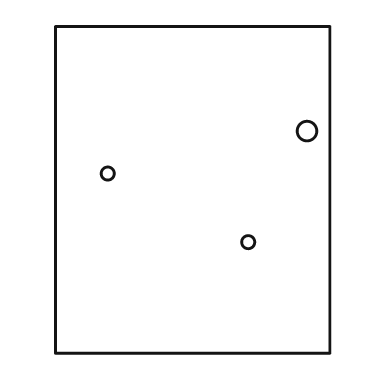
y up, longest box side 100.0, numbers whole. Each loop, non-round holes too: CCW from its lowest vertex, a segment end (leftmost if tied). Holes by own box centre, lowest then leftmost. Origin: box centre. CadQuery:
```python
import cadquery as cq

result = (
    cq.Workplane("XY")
    .moveTo(-42.0, -50.0)
    .lineTo(42.0, -50.0)
    .lineTo(42.0, 50.0)
    .lineTo(-42.0, 50.0)
    .close()
    .moveTo(17.0, -16.0)
    .circle(2.0)
    .moveTo(-26.0, 5.0)
    .circle(2.0)
    .moveTo(35.0, 18.0)
    .circle(3.0)
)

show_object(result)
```